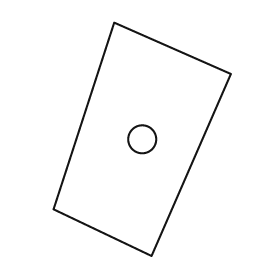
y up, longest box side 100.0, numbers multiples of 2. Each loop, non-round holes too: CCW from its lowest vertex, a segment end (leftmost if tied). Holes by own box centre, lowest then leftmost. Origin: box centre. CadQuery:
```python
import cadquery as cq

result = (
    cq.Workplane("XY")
    .moveTo(4.0, -50.0)
    .lineTo(38.0, 28.0)
    .lineTo(-12.0, 50.0)
    .lineTo(-38.0, -30.0)
    .close()
    .moveTo(0.0, 0.0)
    .circle(6.0)
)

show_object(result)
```